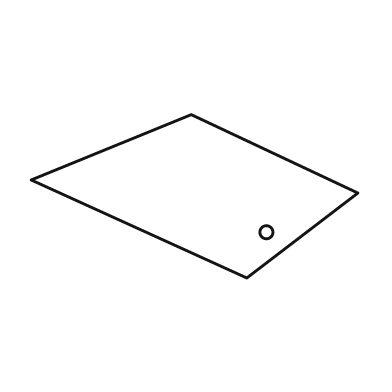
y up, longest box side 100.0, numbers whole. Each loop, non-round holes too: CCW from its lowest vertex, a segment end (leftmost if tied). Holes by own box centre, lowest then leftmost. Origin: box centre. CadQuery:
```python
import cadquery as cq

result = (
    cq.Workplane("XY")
    .moveTo(16.0, -25.0)
    .lineTo(50.0, 1.0)
    .lineTo(-1.0, 25.0)
    .lineTo(-50.0, 5.0)
    .close()
    .moveTo(22.0, -11.0)
    .circle(2.0)
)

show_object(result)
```